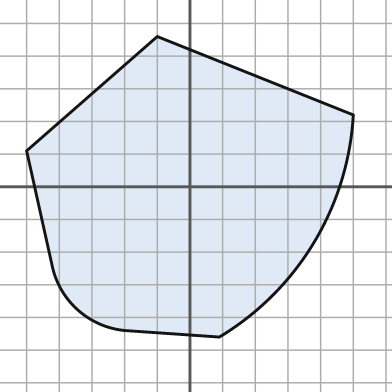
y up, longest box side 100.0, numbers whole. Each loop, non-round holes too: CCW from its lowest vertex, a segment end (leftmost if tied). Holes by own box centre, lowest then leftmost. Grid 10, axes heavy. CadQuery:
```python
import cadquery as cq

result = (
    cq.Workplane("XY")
    .moveTo(9.0, -46.0)
    .threePointArc((38.0, -17.0), (50.0, 22.0))
    .lineTo(-10.0, 46.0)
    .lineTo(-50.0, 11.0)
    .lineTo(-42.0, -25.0)
    .threePointArc((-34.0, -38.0), (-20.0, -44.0))
    .close()
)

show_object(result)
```